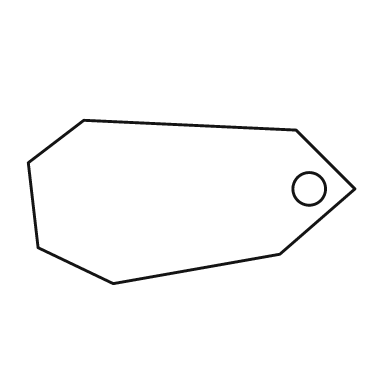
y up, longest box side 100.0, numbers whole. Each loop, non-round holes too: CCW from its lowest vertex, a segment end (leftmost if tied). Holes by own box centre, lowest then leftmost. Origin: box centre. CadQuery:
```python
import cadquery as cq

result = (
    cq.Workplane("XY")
    .moveTo(-24.0, -25.0)
    .lineTo(27.0, -16.0)
    .lineTo(50.0, 4.0)
    .lineTo(32.0, 22.0)
    .lineTo(-33.0, 25.0)
    .lineTo(-50.0, 12.0)
    .lineTo(-47.0, -14.0)
    .close()
    .moveTo(36.0, 4.0)
    .circle(5.0)
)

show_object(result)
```